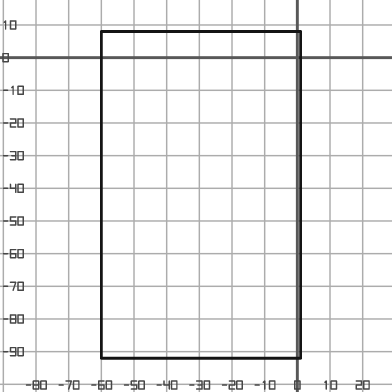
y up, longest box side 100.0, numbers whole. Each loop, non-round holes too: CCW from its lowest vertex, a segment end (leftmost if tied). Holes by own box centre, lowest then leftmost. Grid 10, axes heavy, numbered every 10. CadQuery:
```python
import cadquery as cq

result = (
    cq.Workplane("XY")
    .moveTo(-60.0, -92.0)
    .lineTo(1.0, -92.0)
    .lineTo(1.0, 8.0)
    .lineTo(-60.0, 8.0)
    .close()
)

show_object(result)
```